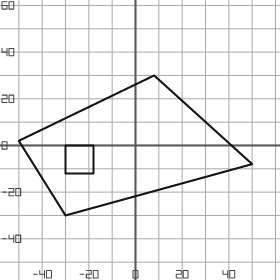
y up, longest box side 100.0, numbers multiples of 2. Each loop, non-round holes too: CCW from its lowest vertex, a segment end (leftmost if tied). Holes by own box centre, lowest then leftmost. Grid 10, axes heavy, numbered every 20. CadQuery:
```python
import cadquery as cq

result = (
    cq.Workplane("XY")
    .moveTo(-30.0, -30.0)
    .lineTo(50.0, -8.0)
    .lineTo(8.0, 30.0)
    .lineTo(-50.0, 2.0)
    .close()
    .moveTo(-30.0, -12.0)
    .lineTo(-18.0, -12.0)
    .lineTo(-18.0, 0.0)
    .lineTo(-30.0, 0.0)
    .close()
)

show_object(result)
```